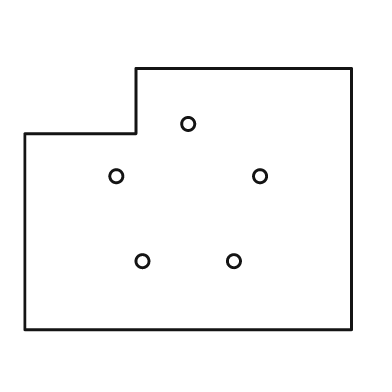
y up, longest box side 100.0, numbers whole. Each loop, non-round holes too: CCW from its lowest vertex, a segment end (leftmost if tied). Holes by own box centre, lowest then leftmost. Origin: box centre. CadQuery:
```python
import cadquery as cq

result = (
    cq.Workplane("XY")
    .moveTo(-50.0, -40.0)
    .lineTo(50.0, -40.0)
    .lineTo(50.0, 40.0)
    .lineTo(-16.0, 40.0)
    .lineTo(-16.0, 20.0)
    .lineTo(-50.0, 20.0)
    .close()
    .moveTo(-14.0, -19.0)
    .circle(2.0)
    .moveTo(14.0, -19.0)
    .circle(2.0)
    .moveTo(-22.0, 7.0)
    .circle(2.0)
    .moveTo(22.0, 7.0)
    .circle(2.0)
    .moveTo(0.0, 23.0)
    .circle(2.0)
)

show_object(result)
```